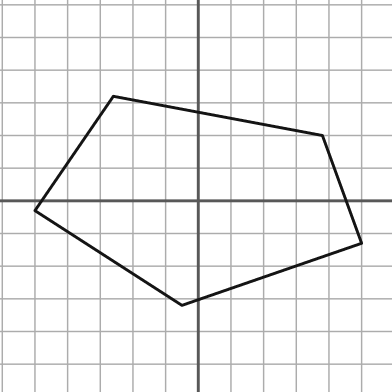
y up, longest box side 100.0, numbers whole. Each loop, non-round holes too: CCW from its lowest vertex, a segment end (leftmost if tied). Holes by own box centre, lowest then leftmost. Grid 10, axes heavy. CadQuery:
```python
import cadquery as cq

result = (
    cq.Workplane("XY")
    .moveTo(-5.0, -32.0)
    .lineTo(50.0, -13.0)
    .lineTo(38.0, 20.0)
    .lineTo(-26.0, 32.0)
    .lineTo(-50.0, -3.0)
    .close()
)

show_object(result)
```